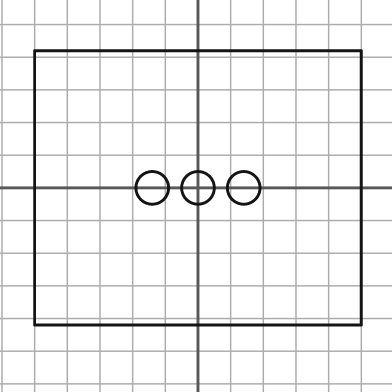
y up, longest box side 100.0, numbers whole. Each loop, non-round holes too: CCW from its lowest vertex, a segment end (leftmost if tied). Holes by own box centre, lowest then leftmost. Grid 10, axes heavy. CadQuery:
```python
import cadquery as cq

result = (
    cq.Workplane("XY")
    .moveTo(-50.0, -42.0)
    .lineTo(50.0, -42.0)
    .lineTo(50.0, 42.0)
    .lineTo(-50.0, 42.0)
    .close()
    .moveTo(-14.0, 0.0)
    .circle(5.0)
    .moveTo(0.0, 0.0)
    .circle(5.0)
    .moveTo(14.0, 0.0)
    .circle(5.0)
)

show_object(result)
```